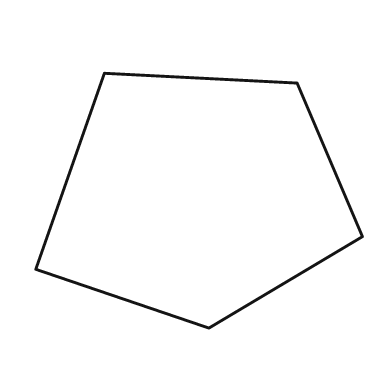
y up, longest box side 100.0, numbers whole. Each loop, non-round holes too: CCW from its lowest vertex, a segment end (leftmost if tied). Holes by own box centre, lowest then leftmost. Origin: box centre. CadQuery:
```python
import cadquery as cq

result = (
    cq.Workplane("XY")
    .moveTo(3.0, -39.0)
    .lineTo(50.0, -11.0)
    .lineTo(30.0, 36.0)
    .lineTo(-29.0, 39.0)
    .lineTo(-50.0, -21.0)
    .close()
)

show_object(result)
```